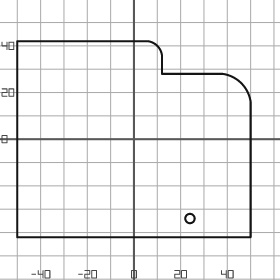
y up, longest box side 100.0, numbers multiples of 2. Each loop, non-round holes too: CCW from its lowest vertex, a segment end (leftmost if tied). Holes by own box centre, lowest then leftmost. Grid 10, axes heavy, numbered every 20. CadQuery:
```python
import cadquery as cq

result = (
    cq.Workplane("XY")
    .moveTo(-50.0, -42.0)
    .lineTo(50.0, -42.0)
    .lineTo(50.0, 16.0)
    .threePointArc((46.0, 24.0), (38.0, 28.0))
    .lineTo(12.0, 28.0)
    .lineTo(12.0, 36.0)
    .threePointArc((10.0, 40.0), (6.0, 42.0))
    .lineTo(-50.0, 42.0)
    .close()
    .moveTo(24.0, -34.0)
    .circle(2.0)
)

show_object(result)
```